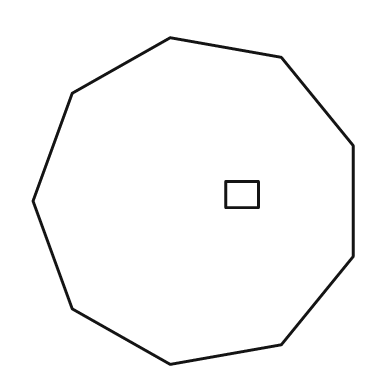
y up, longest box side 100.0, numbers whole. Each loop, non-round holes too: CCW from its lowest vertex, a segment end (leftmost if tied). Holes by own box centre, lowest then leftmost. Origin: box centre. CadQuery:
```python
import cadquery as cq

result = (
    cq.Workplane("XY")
    .moveTo(-7.0, -50.0)
    .lineTo(27.0, -44.0)
    .lineTo(49.0, -17.0)
    .lineTo(49.0, 17.0)
    .lineTo(27.0, 44.0)
    .lineTo(-7.0, 50.0)
    .lineTo(-37.0, 33.0)
    .lineTo(-49.0, 0.0)
    .lineTo(-37.0, -33.0)
    .close()
    .moveTo(10.0, -2.0)
    .lineTo(20.0, -2.0)
    .lineTo(20.0, 6.0)
    .lineTo(10.0, 6.0)
    .close()
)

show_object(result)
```